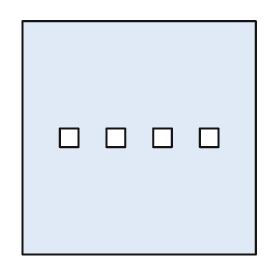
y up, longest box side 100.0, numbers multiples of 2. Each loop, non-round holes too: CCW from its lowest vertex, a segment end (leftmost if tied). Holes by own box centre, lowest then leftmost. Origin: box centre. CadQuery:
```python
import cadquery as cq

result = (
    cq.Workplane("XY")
    .moveTo(-50.0, -50.0)
    .lineTo(50.0, -50.0)
    .lineTo(50.0, 50.0)
    .lineTo(-50.0, 50.0)
    .close()
    .moveTo(-34.0, -4.0)
    .lineTo(-26.0, -4.0)
    .lineTo(-26.0, 4.0)
    .lineTo(-34.0, 4.0)
    .close()
    .moveTo(-14.0, -4.0)
    .lineTo(-6.0, -4.0)
    .lineTo(-6.0, 4.0)
    .lineTo(-14.0, 4.0)
    .close()
    .moveTo(6.0, -4.0)
    .lineTo(14.0, -4.0)
    .lineTo(14.0, 4.0)
    .lineTo(6.0, 4.0)
    .close()
    .moveTo(26.0, -4.0)
    .lineTo(34.0, -4.0)
    .lineTo(34.0, 4.0)
    .lineTo(26.0, 4.0)
    .close()
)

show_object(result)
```